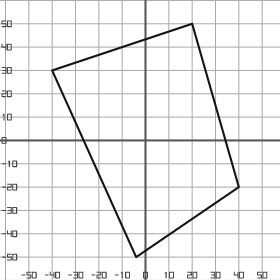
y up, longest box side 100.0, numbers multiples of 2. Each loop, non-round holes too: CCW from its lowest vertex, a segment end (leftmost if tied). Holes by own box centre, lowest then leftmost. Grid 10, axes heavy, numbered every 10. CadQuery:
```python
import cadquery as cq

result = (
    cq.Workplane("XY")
    .moveTo(-4.0, -50.0)
    .lineTo(40.0, -20.0)
    .lineTo(20.0, 50.0)
    .lineTo(-40.0, 30.0)
    .close()
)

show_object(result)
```